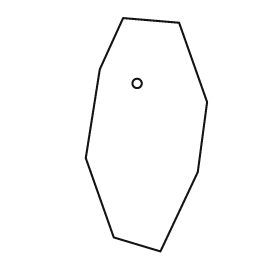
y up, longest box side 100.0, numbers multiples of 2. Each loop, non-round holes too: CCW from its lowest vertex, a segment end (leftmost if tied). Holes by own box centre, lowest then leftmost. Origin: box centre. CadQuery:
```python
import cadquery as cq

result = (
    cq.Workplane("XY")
    .moveTo(6.0, -50.0)
    .lineTo(22.0, -16.0)
    .lineTo(26.0, 14.0)
    .lineTo(14.0, 48.0)
    .lineTo(-10.0, 50.0)
    .lineTo(-20.0, 28.0)
    .lineTo(-26.0, -10.0)
    .lineTo(-14.0, -44.0)
    .close()
    .moveTo(-4.0, 22.0)
    .circle(2.0)
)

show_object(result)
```